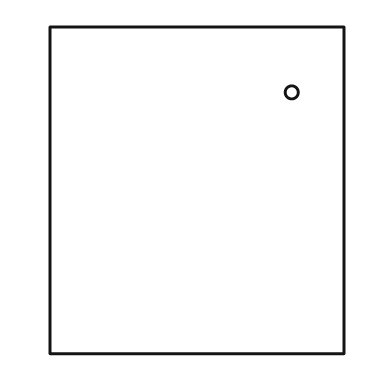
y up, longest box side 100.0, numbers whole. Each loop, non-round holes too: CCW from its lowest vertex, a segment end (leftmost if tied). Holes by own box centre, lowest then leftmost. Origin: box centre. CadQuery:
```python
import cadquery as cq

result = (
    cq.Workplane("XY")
    .moveTo(-45.0, -50.0)
    .lineTo(45.0, -50.0)
    .lineTo(45.0, 50.0)
    .lineTo(-45.0, 50.0)
    .close()
    .moveTo(29.0, 30.0)
    .circle(2.0)
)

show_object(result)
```